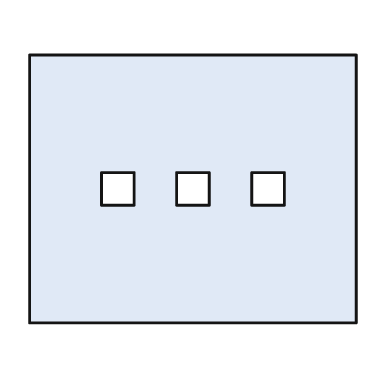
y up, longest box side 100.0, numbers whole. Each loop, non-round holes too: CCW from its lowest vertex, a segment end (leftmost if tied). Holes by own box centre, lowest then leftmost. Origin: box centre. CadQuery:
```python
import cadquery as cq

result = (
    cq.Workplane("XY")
    .moveTo(-50.0, -41.0)
    .lineTo(50.0, -41.0)
    .lineTo(50.0, 41.0)
    .lineTo(-50.0, 41.0)
    .close()
    .moveTo(-28.0, -5.0)
    .lineTo(-18.0, -5.0)
    .lineTo(-18.0, 5.0)
    .lineTo(-28.0, 5.0)
    .close()
    .moveTo(-5.0, -5.0)
    .lineTo(5.0, -5.0)
    .lineTo(5.0, 5.0)
    .lineTo(-5.0, 5.0)
    .close()
    .moveTo(18.0, -5.0)
    .lineTo(28.0, -5.0)
    .lineTo(28.0, 5.0)
    .lineTo(18.0, 5.0)
    .close()
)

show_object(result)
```